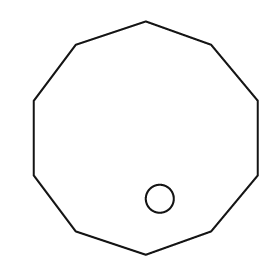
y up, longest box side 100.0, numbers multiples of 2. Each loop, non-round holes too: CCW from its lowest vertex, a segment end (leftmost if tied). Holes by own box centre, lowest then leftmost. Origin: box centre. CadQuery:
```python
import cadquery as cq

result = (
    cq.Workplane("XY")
    .moveTo(0.0, -50.0)
    .lineTo(28.0, -40.0)
    .lineTo(48.0, -16.0)
    .lineTo(48.0, 16.0)
    .lineTo(28.0, 40.0)
    .lineTo(0.0, 50.0)
    .lineTo(-30.0, 40.0)
    .lineTo(-48.0, 16.0)
    .lineTo(-48.0, -16.0)
    .lineTo(-30.0, -40.0)
    .close()
    .moveTo(6.0, -26.0)
    .circle(6.0)
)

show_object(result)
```